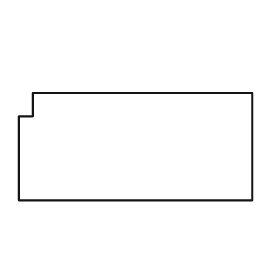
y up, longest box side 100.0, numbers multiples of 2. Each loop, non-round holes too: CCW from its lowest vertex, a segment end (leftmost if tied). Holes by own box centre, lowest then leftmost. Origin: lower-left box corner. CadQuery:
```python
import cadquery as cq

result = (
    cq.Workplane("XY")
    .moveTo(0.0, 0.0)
    .lineTo(100.0, 0.0)
    .lineTo(100.0, 46.0)
    .lineTo(6.0, 46.0)
    .lineTo(6.0, 36.0)
    .lineTo(0.0, 36.0)
    .close()
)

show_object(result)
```